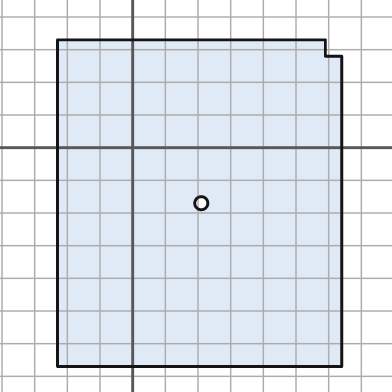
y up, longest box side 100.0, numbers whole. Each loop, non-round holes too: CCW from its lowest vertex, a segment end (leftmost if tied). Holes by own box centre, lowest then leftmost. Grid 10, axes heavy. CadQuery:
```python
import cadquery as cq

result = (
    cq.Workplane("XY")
    .moveTo(-23.0, -67.0)
    .lineTo(64.0, -67.0)
    .lineTo(64.0, 28.0)
    .lineTo(59.0, 28.0)
    .lineTo(59.0, 33.0)
    .lineTo(-23.0, 33.0)
    .close()
    .moveTo(21.0, -17.0)
    .circle(2.0)
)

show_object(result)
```